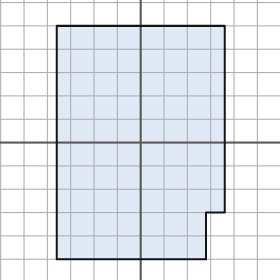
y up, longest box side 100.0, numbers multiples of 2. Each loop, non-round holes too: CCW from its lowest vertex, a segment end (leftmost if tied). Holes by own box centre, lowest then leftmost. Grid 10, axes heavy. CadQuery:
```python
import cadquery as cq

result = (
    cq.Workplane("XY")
    .moveTo(-36.0, -50.0)
    .lineTo(28.0, -50.0)
    .lineTo(28.0, -30.0)
    .lineTo(36.0, -30.0)
    .lineTo(36.0, 50.0)
    .lineTo(-36.0, 50.0)
    .close()
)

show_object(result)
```